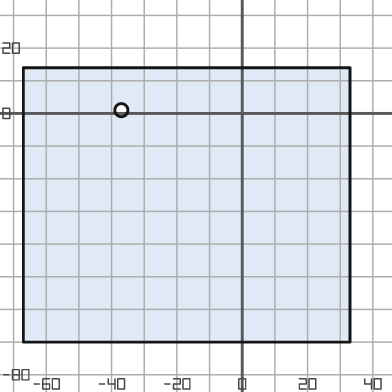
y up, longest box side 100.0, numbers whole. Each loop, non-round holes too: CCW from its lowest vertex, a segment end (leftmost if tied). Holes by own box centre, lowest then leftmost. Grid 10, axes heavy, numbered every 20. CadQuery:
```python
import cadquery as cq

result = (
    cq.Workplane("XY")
    .moveTo(-67.0, -70.0)
    .lineTo(33.0, -70.0)
    .lineTo(33.0, 14.0)
    .lineTo(-67.0, 14.0)
    .close()
    .moveTo(-37.0, 1.0)
    .circle(2.0)
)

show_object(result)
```